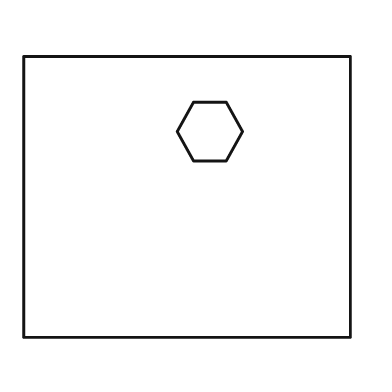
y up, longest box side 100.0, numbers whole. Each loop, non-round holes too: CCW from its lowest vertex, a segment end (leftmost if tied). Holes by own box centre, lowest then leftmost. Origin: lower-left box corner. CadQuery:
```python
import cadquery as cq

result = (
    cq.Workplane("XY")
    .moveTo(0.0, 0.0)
    .lineTo(100.0, 0.0)
    .lineTo(100.0, 86.0)
    .lineTo(0.0, 86.0)
    .close()
    .moveTo(52.0, 54.0)
    .lineTo(62.0, 54.0)
    .lineTo(67.0, 63.0)
    .lineTo(62.0, 72.0)
    .lineTo(52.0, 72.0)
    .lineTo(47.0, 63.0)
    .close()
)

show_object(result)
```